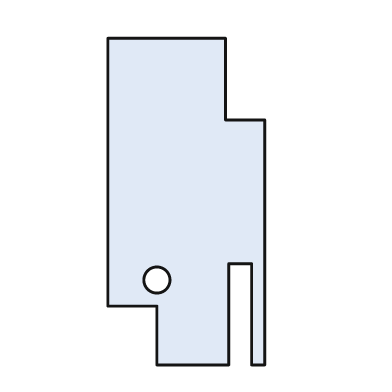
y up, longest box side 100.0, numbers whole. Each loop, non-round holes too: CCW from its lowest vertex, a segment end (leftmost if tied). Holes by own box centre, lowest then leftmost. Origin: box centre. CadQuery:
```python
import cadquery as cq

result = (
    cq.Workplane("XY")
    .moveTo(-9.0, -50.0)
    .lineTo(13.0, -50.0)
    .lineTo(13.0, -19.0)
    .lineTo(20.0, -19.0)
    .lineTo(20.0, -50.0)
    .lineTo(24.0, -50.0)
    .lineTo(24.0, 25.0)
    .lineTo(12.0, 25.0)
    .lineTo(12.0, 50.0)
    .lineTo(-24.0, 50.0)
    .lineTo(-24.0, -32.0)
    .lineTo(-9.0, -32.0)
    .close()
    .moveTo(-9.0, -24.0)
    .circle(4.0)
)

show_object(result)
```